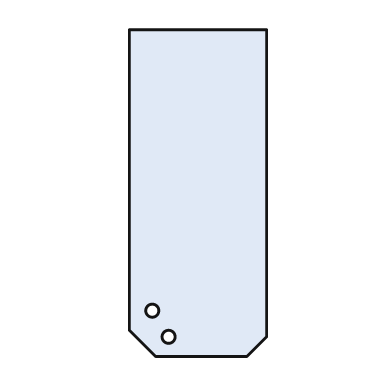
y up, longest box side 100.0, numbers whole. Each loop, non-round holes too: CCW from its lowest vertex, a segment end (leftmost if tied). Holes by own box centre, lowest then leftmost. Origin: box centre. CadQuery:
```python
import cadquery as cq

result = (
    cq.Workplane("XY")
    .moveTo(-13.0, -50.0)
    .lineTo(15.0, -50.0)
    .lineTo(21.0, -44.0)
    .lineTo(21.0, 50.0)
    .lineTo(-21.0, 50.0)
    .lineTo(-21.0, -42.0)
    .close()
    .moveTo(-9.0, -44.0)
    .circle(2.0)
    .moveTo(-14.0, -36.0)
    .circle(2.0)
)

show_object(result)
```